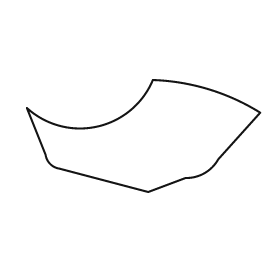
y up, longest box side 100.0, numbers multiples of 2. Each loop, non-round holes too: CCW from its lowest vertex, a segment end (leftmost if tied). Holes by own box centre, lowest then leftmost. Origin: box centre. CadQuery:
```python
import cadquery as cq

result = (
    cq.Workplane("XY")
    .moveTo(2.0, -24.0)
    .lineTo(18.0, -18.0)
    .threePointArc((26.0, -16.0), (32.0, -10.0))
    .lineTo(50.0, 10.0)
    .threePointArc((28.0, 20.0), (4.0, 24.0))
    .threePointArc((-20.0, 4.0), (-50.0, 12.0))
    .lineTo(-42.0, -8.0)
    .threePointArc((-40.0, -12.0), (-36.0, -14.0))
    .close()
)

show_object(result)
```